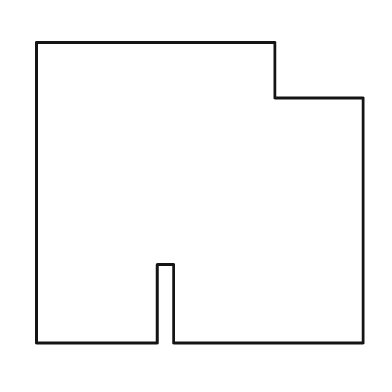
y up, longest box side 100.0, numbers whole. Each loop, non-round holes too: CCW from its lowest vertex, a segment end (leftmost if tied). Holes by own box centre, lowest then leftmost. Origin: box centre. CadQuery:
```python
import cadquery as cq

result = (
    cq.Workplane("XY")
    .moveTo(-50.0, -46.0)
    .lineTo(-13.0, -46.0)
    .lineTo(-13.0, -22.0)
    .lineTo(-8.0, -22.0)
    .lineTo(-8.0, -46.0)
    .lineTo(50.0, -46.0)
    .lineTo(50.0, 29.0)
    .lineTo(23.0, 29.0)
    .lineTo(23.0, 46.0)
    .lineTo(-50.0, 46.0)
    .close()
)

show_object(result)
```